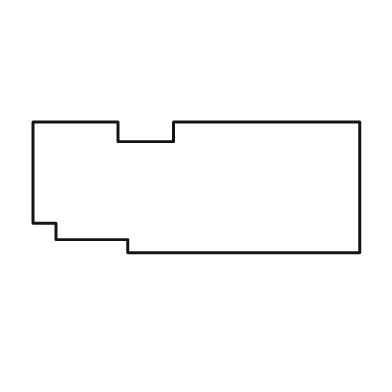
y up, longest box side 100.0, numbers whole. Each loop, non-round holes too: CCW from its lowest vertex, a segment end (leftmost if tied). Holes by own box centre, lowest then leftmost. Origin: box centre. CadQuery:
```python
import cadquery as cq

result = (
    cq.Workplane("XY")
    .moveTo(-21.0, -20.0)
    .lineTo(50.0, -20.0)
    .lineTo(50.0, 20.0)
    .lineTo(-7.0, 20.0)
    .lineTo(-7.0, 14.0)
    .lineTo(-24.0, 14.0)
    .lineTo(-24.0, 20.0)
    .lineTo(-50.0, 20.0)
    .lineTo(-50.0, -11.0)
    .lineTo(-43.0, -11.0)
    .lineTo(-43.0, -16.0)
    .lineTo(-21.0, -16.0)
    .close()
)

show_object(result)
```